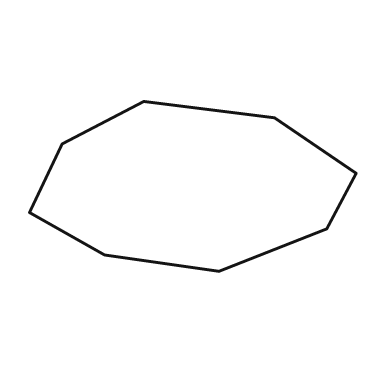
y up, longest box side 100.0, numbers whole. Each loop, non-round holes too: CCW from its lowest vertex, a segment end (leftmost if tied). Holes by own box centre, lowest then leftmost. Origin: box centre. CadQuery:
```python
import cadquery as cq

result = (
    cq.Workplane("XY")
    .moveTo(8.0, -26.0)
    .lineTo(41.0, -13.0)
    .lineTo(50.0, 4.0)
    .lineTo(25.0, 21.0)
    .lineTo(-15.0, 26.0)
    .lineTo(-40.0, 13.0)
    .lineTo(-50.0, -8.0)
    .lineTo(-27.0, -21.0)
    .close()
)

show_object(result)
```